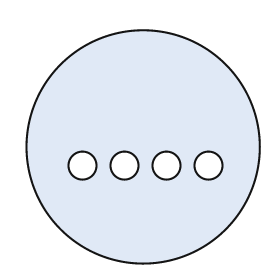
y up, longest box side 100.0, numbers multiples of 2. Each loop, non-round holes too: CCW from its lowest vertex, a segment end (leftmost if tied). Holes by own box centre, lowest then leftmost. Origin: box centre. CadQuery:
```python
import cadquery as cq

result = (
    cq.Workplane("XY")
    .moveTo(0.0, 0.0)
    .circle(50.0)
    .moveTo(-26.0, -8.0)
    .circle(6.0)
    .moveTo(-8.0, -8.0)
    .circle(6.0)
    .moveTo(10.0, -8.0)
    .circle(6.0)
    .moveTo(28.0, -8.0)
    .circle(6.0)
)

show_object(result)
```